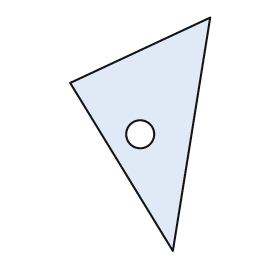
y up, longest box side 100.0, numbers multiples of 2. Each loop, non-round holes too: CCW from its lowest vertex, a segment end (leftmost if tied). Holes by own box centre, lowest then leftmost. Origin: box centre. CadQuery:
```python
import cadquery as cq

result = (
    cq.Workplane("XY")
    .moveTo(14.0, -50.0)
    .lineTo(30.0, 50.0)
    .lineTo(-30.0, 22.0)
    .close()
    .moveTo(0.0, 0.0)
    .circle(6.0)
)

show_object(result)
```